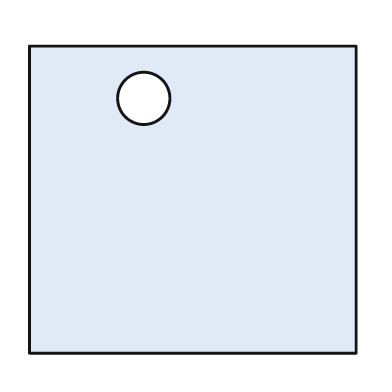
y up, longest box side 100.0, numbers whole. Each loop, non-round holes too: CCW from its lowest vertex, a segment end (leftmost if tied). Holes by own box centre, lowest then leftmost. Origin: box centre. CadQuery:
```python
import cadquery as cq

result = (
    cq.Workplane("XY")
    .moveTo(-50.0, -47.0)
    .lineTo(50.0, -47.0)
    .lineTo(50.0, 47.0)
    .lineTo(-50.0, 47.0)
    .close()
    .moveTo(-15.0, 31.0)
    .circle(8.0)
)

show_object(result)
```